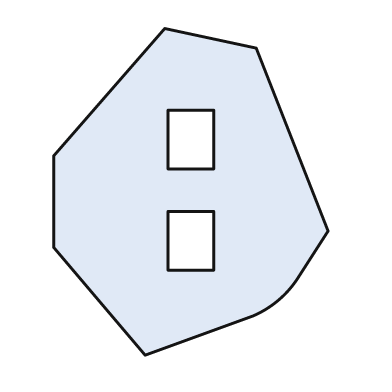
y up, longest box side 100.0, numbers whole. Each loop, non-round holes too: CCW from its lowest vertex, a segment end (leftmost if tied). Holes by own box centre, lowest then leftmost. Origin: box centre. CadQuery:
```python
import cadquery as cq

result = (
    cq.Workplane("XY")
    .moveTo(-14.0, -50.0)
    .lineTo(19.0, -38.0)
    .threePointArc((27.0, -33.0), (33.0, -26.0))
    .lineTo(42.0, -12.0)
    .lineTo(20.0, 44.0)
    .lineTo(-8.0, 50.0)
    .lineTo(-42.0, 11.0)
    .lineTo(-42.0, -17.0)
    .close()
    .moveTo(-7.0, -24.0)
    .lineTo(7.0, -24.0)
    .lineTo(7.0, -6.0)
    .lineTo(-7.0, -6.0)
    .close()
    .moveTo(-7.0, 7.0)
    .lineTo(7.0, 7.0)
    .lineTo(7.0, 25.0)
    .lineTo(-7.0, 25.0)
    .close()
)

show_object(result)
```